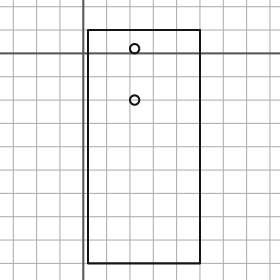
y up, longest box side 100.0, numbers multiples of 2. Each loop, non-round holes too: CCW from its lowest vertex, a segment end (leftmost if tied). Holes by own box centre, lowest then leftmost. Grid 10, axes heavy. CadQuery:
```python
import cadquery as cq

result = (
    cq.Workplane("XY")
    .moveTo(2.0, -90.0)
    .lineTo(50.0, -90.0)
    .lineTo(50.0, 10.0)
    .lineTo(2.0, 10.0)
    .close()
    .moveTo(22.0, -20.0)
    .circle(2.0)
    .moveTo(22.0, 2.0)
    .circle(2.0)
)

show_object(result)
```